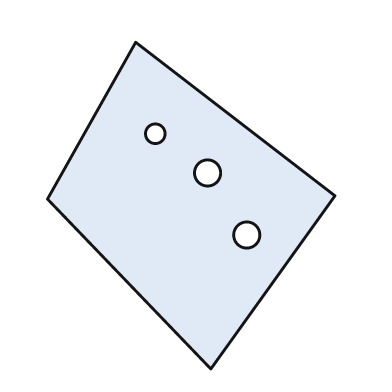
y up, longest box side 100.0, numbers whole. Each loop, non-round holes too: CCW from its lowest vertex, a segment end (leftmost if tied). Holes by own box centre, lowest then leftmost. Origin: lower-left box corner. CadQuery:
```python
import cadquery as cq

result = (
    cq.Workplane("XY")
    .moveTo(50.0, 0.0)
    .lineTo(88.0, 53.0)
    .lineTo(27.0, 100.0)
    .lineTo(0.0, 52.0)
    .close()
    .moveTo(61.0, 41.0)
    .circle(4.0)
    .moveTo(49.0, 60.0)
    .circle(4.0)
    .moveTo(33.0, 72.0)
    .circle(3.0)
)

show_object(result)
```